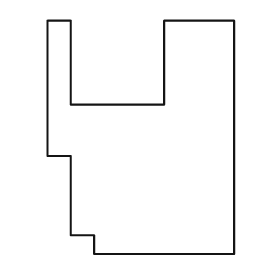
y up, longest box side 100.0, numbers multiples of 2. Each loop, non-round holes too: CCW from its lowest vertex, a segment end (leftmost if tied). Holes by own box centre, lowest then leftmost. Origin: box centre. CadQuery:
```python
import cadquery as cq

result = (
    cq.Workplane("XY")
    .moveTo(-20.0, -50.0)
    .lineTo(40.0, -50.0)
    .lineTo(40.0, 50.0)
    .lineTo(10.0, 50.0)
    .lineTo(10.0, 14.0)
    .lineTo(-30.0, 14.0)
    .lineTo(-30.0, 50.0)
    .lineTo(-40.0, 50.0)
    .lineTo(-40.0, -8.0)
    .lineTo(-30.0, -8.0)
    .lineTo(-30.0, -42.0)
    .lineTo(-20.0, -42.0)
    .close()
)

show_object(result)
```